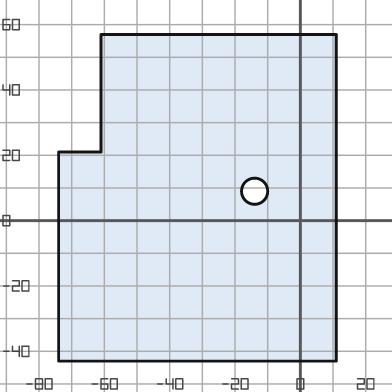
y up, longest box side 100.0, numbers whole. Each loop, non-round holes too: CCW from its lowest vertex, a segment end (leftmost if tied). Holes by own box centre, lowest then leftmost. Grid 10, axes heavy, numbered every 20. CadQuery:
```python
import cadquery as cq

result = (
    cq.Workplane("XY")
    .moveTo(-74.0, -43.0)
    .lineTo(11.0, -43.0)
    .lineTo(11.0, 57.0)
    .lineTo(-61.0, 57.0)
    .lineTo(-61.0, 21.0)
    .lineTo(-74.0, 21.0)
    .close()
    .moveTo(-14.0, 9.0)
    .circle(4.0)
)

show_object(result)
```